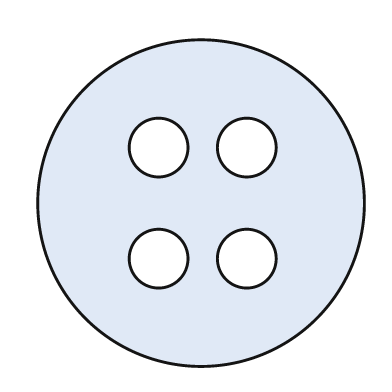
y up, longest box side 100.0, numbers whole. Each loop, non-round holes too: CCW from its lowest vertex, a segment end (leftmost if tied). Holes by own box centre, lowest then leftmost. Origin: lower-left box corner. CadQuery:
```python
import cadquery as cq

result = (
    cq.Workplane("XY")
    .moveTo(50.0, 50.0)
    .circle(50.0)
    .moveTo(37.0, 33.0)
    .circle(9.0)
    .moveTo(64.0, 33.0)
    .circle(9.0)
    .moveTo(37.0, 67.0)
    .circle(9.0)
    .moveTo(64.0, 67.0)
    .circle(9.0)
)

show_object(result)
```